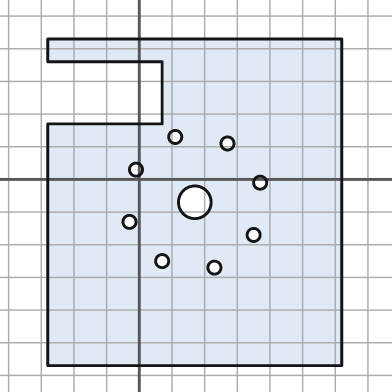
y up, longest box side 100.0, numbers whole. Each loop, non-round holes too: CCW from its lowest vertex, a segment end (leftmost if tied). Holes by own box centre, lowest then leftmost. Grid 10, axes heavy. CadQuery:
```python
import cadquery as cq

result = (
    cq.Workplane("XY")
    .moveTo(-28.0, -57.0)
    .lineTo(62.0, -57.0)
    .lineTo(62.0, 43.0)
    .lineTo(-28.0, 43.0)
    .lineTo(-28.0, 36.0)
    .lineTo(7.0, 36.0)
    .lineTo(7.0, 17.0)
    .lineTo(-28.0, 17.0)
    .close()
    .moveTo(23.0, -27.0)
    .circle(2.0)
    .moveTo(7.0, -25.0)
    .circle(2.0)
    .moveTo(35.0, -17.0)
    .circle(2.0)
    .moveTo(-3.0, -13.0)
    .circle(2.0)
    .moveTo(17.0, -7.0)
    .circle(5.0)
    .moveTo(37.0, -1.0)
    .circle(2.0)
    .moveTo(-1.0, 3.0)
    .circle(2.0)
    .moveTo(27.0, 11.0)
    .circle(2.0)
    .moveTo(11.0, 13.0)
    .circle(2.0)
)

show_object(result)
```